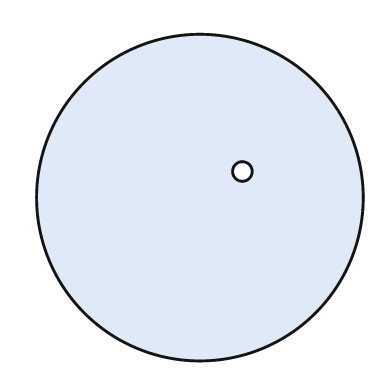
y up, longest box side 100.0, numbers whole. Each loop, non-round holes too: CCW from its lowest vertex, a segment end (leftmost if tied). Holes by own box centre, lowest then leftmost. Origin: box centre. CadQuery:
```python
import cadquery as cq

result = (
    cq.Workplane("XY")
    .moveTo(0.0, 0.0)
    .circle(50.0)
    .moveTo(13.0, 8.0)
    .circle(3.0)
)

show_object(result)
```